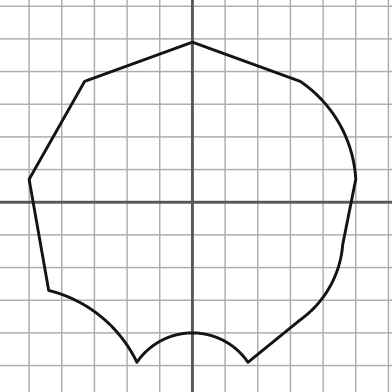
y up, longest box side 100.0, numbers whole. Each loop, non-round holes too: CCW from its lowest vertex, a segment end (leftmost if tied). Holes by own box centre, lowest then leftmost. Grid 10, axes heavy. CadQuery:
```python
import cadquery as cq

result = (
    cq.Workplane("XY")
    .moveTo(-17.0, -49.0)
    .threePointArc((0.0, -40.0), (17.0, -49.0))
    .lineTo(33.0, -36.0)
    .threePointArc((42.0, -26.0), (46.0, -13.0))
    .lineTo(50.0, 7.0)
    .threePointArc((45.0, 24.0), (33.0, 37.0))
    .lineTo(0.0, 49.0)
    .lineTo(-33.0, 37.0)
    .lineTo(-50.0, 7.0)
    .lineTo(-44.0, -27.0)
    .threePointArc((-28.0, -35.0), (-17.0, -49.0))
    .close()
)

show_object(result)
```